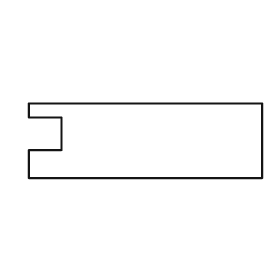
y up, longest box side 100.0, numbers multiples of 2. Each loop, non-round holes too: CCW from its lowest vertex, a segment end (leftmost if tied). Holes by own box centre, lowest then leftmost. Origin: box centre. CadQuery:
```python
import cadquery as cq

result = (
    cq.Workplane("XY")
    .moveTo(-50.0, -16.0)
    .lineTo(50.0, -16.0)
    .lineTo(50.0, 16.0)
    .lineTo(-50.0, 16.0)
    .lineTo(-50.0, 10.0)
    .lineTo(-36.0, 10.0)
    .lineTo(-36.0, -4.0)
    .lineTo(-50.0, -4.0)
    .close()
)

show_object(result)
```